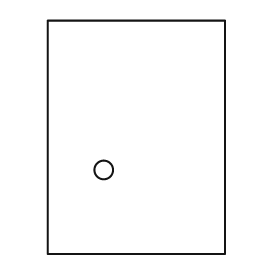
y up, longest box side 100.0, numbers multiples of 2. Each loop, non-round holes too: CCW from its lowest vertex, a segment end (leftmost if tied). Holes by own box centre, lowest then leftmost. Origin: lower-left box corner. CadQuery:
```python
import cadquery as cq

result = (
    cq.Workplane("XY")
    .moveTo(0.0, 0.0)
    .lineTo(76.0, 0.0)
    .lineTo(76.0, 100.0)
    .lineTo(0.0, 100.0)
    .close()
    .moveTo(24.0, 36.0)
    .circle(4.0)
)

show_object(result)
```